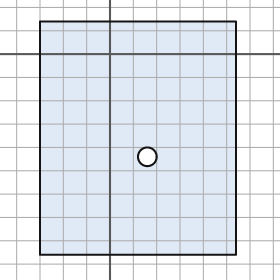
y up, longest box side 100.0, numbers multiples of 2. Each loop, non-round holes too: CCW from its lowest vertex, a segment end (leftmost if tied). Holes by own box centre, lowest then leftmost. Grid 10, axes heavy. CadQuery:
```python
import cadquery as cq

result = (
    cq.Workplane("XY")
    .moveTo(-30.0, -86.0)
    .lineTo(54.0, -86.0)
    .lineTo(54.0, 14.0)
    .lineTo(-30.0, 14.0)
    .close()
    .moveTo(16.0, -44.0)
    .circle(4.0)
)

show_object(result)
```